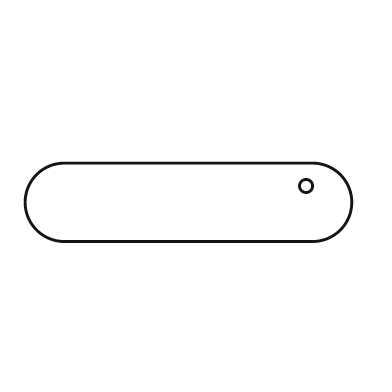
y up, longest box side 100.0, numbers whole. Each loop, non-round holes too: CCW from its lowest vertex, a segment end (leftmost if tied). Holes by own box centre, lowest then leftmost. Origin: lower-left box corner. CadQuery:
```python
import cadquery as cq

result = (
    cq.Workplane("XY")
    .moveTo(12.0, 0.0)
    .lineTo(88.0, 0.0)
    .threePointArc((100.0, 12.0), (88.0, 24.0))
    .lineTo(12.0, 24.0)
    .threePointArc((0.0, 12.0), (12.0, 0.0))
    .close()
    .moveTo(86.0, 17.0)
    .circle(2.0)
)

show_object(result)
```